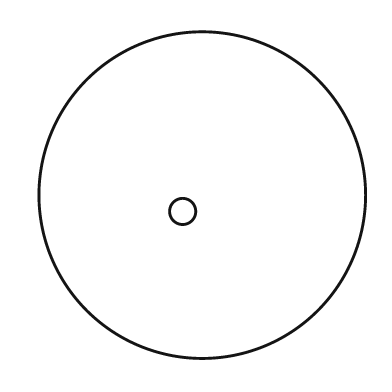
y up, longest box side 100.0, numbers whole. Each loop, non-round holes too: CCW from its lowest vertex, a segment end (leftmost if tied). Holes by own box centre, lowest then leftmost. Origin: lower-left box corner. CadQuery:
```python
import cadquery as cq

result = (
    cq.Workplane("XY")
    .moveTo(50.0, 50.0)
    .circle(50.0)
    .moveTo(44.0, 45.0)
    .circle(4.0)
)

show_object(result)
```